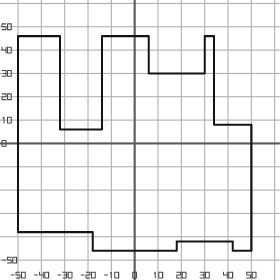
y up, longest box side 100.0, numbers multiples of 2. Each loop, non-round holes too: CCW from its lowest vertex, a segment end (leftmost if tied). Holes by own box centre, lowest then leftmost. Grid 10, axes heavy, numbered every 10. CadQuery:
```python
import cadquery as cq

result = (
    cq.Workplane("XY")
    .moveTo(-18.0, -46.0)
    .lineTo(18.0, -46.0)
    .lineTo(18.0, -42.0)
    .lineTo(42.0, -42.0)
    .lineTo(42.0, -46.0)
    .lineTo(50.0, -46.0)
    .lineTo(50.0, 8.0)
    .lineTo(34.0, 8.0)
    .lineTo(34.0, 46.0)
    .lineTo(30.0, 46.0)
    .lineTo(30.0, 30.0)
    .lineTo(6.0, 30.0)
    .lineTo(6.0, 46.0)
    .lineTo(-14.0, 46.0)
    .lineTo(-14.0, 6.0)
    .lineTo(-32.0, 6.0)
    .lineTo(-32.0, 46.0)
    .lineTo(-50.0, 46.0)
    .lineTo(-50.0, -38.0)
    .lineTo(-18.0, -38.0)
    .close()
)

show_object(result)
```